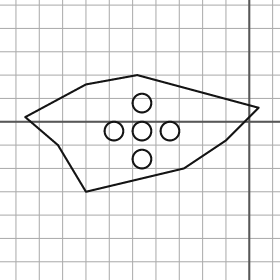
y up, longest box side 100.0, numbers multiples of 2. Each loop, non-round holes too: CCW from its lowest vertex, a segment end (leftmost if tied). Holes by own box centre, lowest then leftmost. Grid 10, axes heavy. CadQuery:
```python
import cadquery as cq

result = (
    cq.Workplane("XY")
    .moveTo(-70.0, -30.0)
    .lineTo(-28.0, -20.0)
    .lineTo(-10.0, -8.0)
    .lineTo(4.0, 6.0)
    .lineTo(-48.0, 20.0)
    .lineTo(-70.0, 16.0)
    .lineTo(-96.0, 2.0)
    .lineTo(-82.0, -10.0)
    .close()
    .moveTo(-46.0, -16.0)
    .circle(4.0)
    .moveTo(-58.0, -4.0)
    .circle(4.0)
    .moveTo(-46.0, -4.0)
    .circle(4.0)
    .moveTo(-34.0, -4.0)
    .circle(4.0)
    .moveTo(-46.0, 8.0)
    .circle(4.0)
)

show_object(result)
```